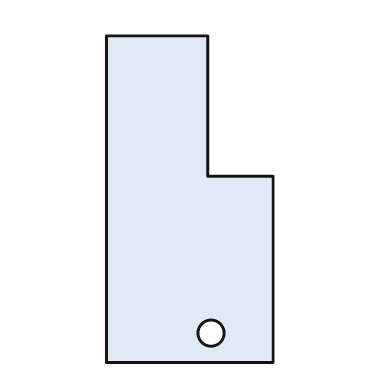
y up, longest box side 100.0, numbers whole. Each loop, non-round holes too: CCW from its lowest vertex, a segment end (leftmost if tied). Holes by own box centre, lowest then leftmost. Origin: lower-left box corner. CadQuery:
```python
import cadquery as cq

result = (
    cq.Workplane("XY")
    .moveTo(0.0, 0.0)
    .lineTo(51.0, 0.0)
    .lineTo(51.0, 57.0)
    .lineTo(31.0, 57.0)
    .lineTo(31.0, 100.0)
    .lineTo(0.0, 100.0)
    .close()
    .moveTo(32.0, 9.0)
    .circle(4.0)
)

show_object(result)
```